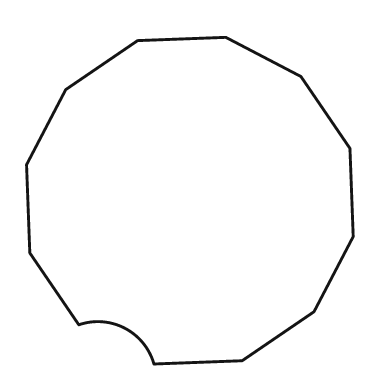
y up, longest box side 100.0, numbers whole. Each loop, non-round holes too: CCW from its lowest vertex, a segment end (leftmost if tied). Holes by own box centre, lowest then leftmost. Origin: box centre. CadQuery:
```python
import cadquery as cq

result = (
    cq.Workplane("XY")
    .moveTo(-11.0, -50.0)
    .lineTo(16.0, -49.0)
    .lineTo(38.0, -34.0)
    .lineTo(50.0, -11.0)
    .lineTo(49.0, 16.0)
    .lineTo(34.0, 38.0)
    .lineTo(11.0, 50.0)
    .lineTo(-16.0, 49.0)
    .lineTo(-38.0, 34.0)
    .lineTo(-50.0, 11.0)
    .lineTo(-49.0, -16.0)
    .lineTo(-34.0, -38.0)
    .threePointArc((-20.0, -39.0), (-11.0, -50.0))
    .close()
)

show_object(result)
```